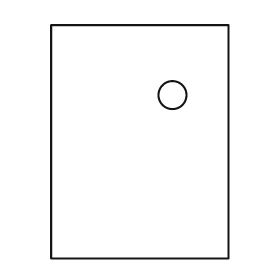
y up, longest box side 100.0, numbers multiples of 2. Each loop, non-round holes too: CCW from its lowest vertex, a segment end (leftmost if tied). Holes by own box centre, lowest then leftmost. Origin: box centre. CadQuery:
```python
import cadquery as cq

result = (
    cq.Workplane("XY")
    .moveTo(-38.0, -50.0)
    .lineTo(38.0, -50.0)
    .lineTo(38.0, 50.0)
    .lineTo(-38.0, 50.0)
    .close()
    .moveTo(14.0, 20.0)
    .circle(6.0)
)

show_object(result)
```